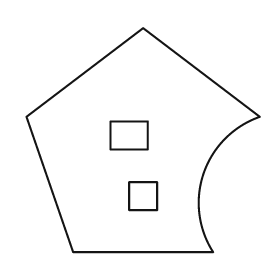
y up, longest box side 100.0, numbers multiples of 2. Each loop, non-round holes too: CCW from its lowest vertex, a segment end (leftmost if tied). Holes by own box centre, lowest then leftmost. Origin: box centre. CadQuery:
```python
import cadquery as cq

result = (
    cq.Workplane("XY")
    .moveTo(-30.0, -48.0)
    .lineTo(30.0, -48.0)
    .threePointArc((26.0, -14.0), (50.0, 10.0))
    .lineTo(0.0, 48.0)
    .lineTo(-50.0, 10.0)
    .close()
    .moveTo(-6.0, -30.0)
    .lineTo(6.0, -30.0)
    .lineTo(6.0, -18.0)
    .lineTo(-6.0, -18.0)
    .close()
    .moveTo(-14.0, -4.0)
    .lineTo(2.0, -4.0)
    .lineTo(2.0, 8.0)
    .lineTo(-14.0, 8.0)
    .close()
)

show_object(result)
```